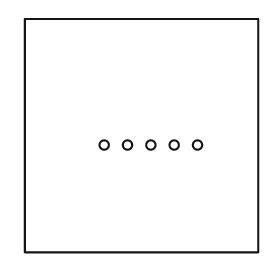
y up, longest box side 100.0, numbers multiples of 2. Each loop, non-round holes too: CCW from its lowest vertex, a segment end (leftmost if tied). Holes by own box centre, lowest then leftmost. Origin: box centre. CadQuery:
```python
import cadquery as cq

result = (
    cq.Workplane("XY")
    .moveTo(-50.0, -50.0)
    .lineTo(50.0, -50.0)
    .lineTo(50.0, 50.0)
    .lineTo(-50.0, 50.0)
    .close()
    .moveTo(-16.0, -4.0)
    .circle(2.0)
    .moveTo(-6.0, -4.0)
    .circle(2.0)
    .moveTo(4.0, -4.0)
    .circle(2.0)
    .moveTo(14.0, -4.0)
    .circle(2.0)
    .moveTo(24.0, -4.0)
    .circle(2.0)
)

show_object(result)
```